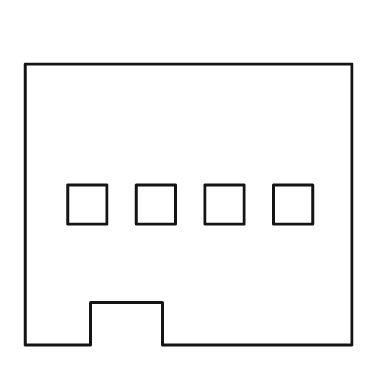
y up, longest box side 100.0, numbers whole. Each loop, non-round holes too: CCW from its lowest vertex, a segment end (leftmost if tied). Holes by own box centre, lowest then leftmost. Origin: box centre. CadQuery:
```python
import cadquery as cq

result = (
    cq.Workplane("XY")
    .moveTo(-50.0, -43.0)
    .lineTo(-30.0, -43.0)
    .lineTo(-30.0, -30.0)
    .lineTo(-8.0, -30.0)
    .lineTo(-8.0, -43.0)
    .lineTo(50.0, -43.0)
    .lineTo(50.0, 43.0)
    .lineTo(-50.0, 43.0)
    .close()
    .moveTo(-37.0, -6.0)
    .lineTo(-25.0, -6.0)
    .lineTo(-25.0, 6.0)
    .lineTo(-37.0, 6.0)
    .close()
    .moveTo(-16.0, -6.0)
    .lineTo(-4.0, -6.0)
    .lineTo(-4.0, 6.0)
    .lineTo(-16.0, 6.0)
    .close()
    .moveTo(5.0, -6.0)
    .lineTo(17.0, -6.0)
    .lineTo(17.0, 6.0)
    .lineTo(5.0, 6.0)
    .close()
    .moveTo(26.0, -6.0)
    .lineTo(38.0, -6.0)
    .lineTo(38.0, 6.0)
    .lineTo(26.0, 6.0)
    .close()
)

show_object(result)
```